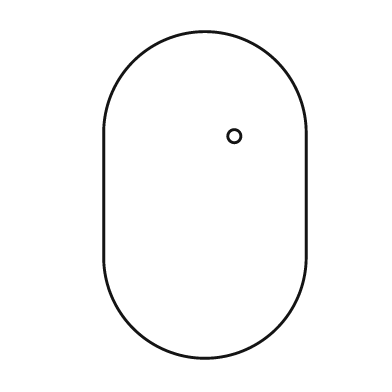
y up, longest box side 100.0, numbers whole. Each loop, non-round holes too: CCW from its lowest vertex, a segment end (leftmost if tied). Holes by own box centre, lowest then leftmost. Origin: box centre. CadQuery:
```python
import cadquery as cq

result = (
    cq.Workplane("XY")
    .moveTo(-31.0, -19.0)
    .threePointArc((0.0, -50.0), (31.0, -19.0))
    .lineTo(31.0, 19.0)
    .threePointArc((0.0, 50.0), (-31.0, 19.0))
    .close()
    .moveTo(9.0, 18.0)
    .circle(2.0)
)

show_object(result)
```